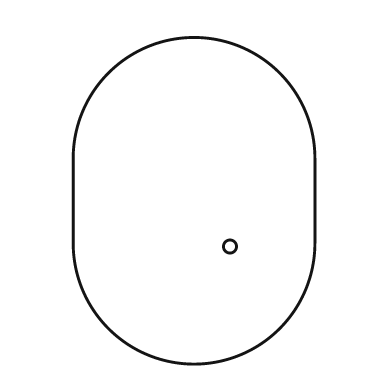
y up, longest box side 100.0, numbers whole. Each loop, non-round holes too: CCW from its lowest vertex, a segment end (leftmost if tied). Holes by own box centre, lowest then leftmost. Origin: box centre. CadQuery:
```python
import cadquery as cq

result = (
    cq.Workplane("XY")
    .moveTo(-37.0, -13.0)
    .threePointArc((0.0, -50.0), (37.0, -13.0))
    .lineTo(37.0, 13.0)
    .threePointArc((0.0, 50.0), (-37.0, 13.0))
    .close()
    .moveTo(11.0, -14.0)
    .circle(2.0)
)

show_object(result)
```